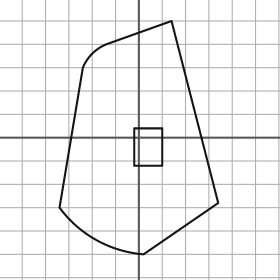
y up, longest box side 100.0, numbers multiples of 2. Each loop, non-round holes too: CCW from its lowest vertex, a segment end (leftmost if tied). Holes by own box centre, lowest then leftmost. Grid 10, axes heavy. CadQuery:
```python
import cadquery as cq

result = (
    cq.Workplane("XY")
    .moveTo(2.0, -50.0)
    .lineTo(34.0, -28.0)
    .lineTo(14.0, 50.0)
    .lineTo(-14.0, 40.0)
    .threePointArc((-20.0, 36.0), (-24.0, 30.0))
    .lineTo(-34.0, -30.0)
    .threePointArc((-18.0, -44.0), (2.0, -50.0))
    .close()
    .moveTo(-2.0, -12.0)
    .lineTo(10.0, -12.0)
    .lineTo(10.0, 4.0)
    .lineTo(-2.0, 4.0)
    .close()
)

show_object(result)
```